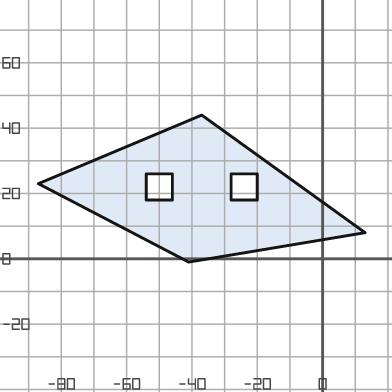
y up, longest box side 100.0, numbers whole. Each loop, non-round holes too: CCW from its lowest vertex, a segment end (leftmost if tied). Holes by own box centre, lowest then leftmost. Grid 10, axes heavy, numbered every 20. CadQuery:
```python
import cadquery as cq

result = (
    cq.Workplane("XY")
    .moveTo(-41.0, -1.0)
    .lineTo(13.0, 8.0)
    .lineTo(-37.0, 44.0)
    .lineTo(-87.0, 23.0)
    .close()
    .moveTo(-54.0, 18.0)
    .lineTo(-46.0, 18.0)
    .lineTo(-46.0, 26.0)
    .lineTo(-54.0, 26.0)
    .close()
    .moveTo(-28.0, 18.0)
    .lineTo(-20.0, 18.0)
    .lineTo(-20.0, 26.0)
    .lineTo(-28.0, 26.0)
    .close()
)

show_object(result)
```